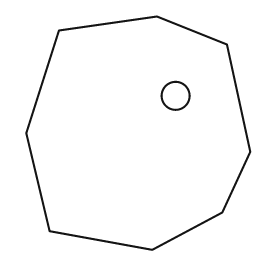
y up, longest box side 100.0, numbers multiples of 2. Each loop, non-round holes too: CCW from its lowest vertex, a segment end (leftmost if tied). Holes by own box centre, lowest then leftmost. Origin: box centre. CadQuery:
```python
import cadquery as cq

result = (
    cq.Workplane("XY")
    .moveTo(6.0, -50.0)
    .lineTo(36.0, -34.0)
    .lineTo(48.0, -8.0)
    .lineTo(38.0, 38.0)
    .lineTo(8.0, 50.0)
    .lineTo(-34.0, 44.0)
    .lineTo(-48.0, 0.0)
    .lineTo(-38.0, -42.0)
    .close()
    .moveTo(16.0, 16.0)
    .circle(6.0)
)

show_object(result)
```